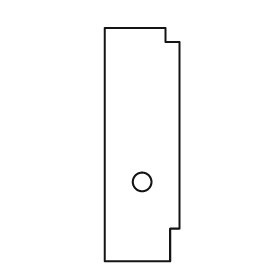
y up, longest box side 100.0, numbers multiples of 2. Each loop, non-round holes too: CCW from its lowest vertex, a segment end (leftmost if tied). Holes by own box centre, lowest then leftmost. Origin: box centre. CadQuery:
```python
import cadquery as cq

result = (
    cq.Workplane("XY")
    .moveTo(-16.0, -50.0)
    .lineTo(12.0, -50.0)
    .lineTo(12.0, -36.0)
    .lineTo(16.0, -36.0)
    .lineTo(16.0, 44.0)
    .lineTo(10.0, 44.0)
    .lineTo(10.0, 50.0)
    .lineTo(-16.0, 50.0)
    .close()
    .moveTo(0.0, -16.0)
    .circle(4.0)
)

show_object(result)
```